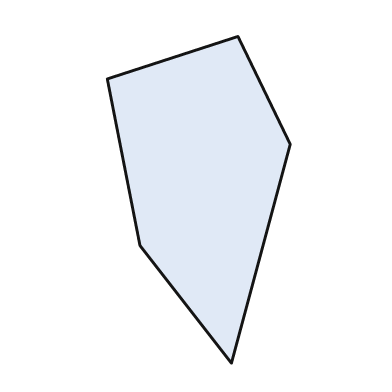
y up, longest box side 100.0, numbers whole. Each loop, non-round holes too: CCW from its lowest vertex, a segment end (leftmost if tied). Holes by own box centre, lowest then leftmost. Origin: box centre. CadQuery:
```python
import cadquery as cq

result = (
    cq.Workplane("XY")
    .moveTo(10.0, -50.0)
    .lineTo(28.0, 17.0)
    .lineTo(12.0, 50.0)
    .lineTo(-28.0, 37.0)
    .lineTo(-18.0, -14.0)
    .close()
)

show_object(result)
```